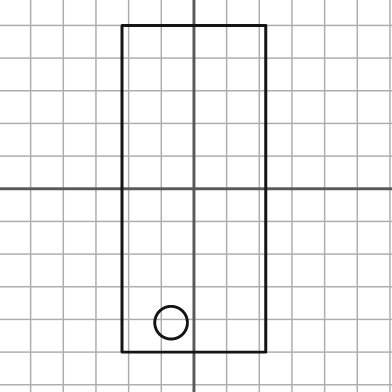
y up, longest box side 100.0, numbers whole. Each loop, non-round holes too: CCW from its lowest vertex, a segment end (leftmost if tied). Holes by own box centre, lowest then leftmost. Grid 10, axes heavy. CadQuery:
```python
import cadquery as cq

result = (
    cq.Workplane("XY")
    .moveTo(-22.0, -50.0)
    .lineTo(22.0, -50.0)
    .lineTo(22.0, 50.0)
    .lineTo(-22.0, 50.0)
    .close()
    .moveTo(-7.0, -41.0)
    .circle(5.0)
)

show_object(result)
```